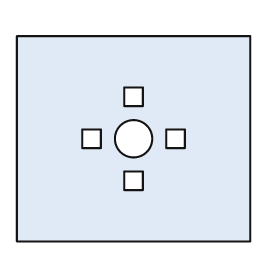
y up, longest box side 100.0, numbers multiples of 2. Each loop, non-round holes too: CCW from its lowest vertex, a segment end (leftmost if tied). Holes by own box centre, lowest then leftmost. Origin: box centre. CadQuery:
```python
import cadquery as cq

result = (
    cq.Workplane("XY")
    .moveTo(-50.0, -44.0)
    .lineTo(50.0, -44.0)
    .lineTo(50.0, 44.0)
    .lineTo(-50.0, 44.0)
    .close()
    .moveTo(-4.0, -22.0)
    .lineTo(4.0, -22.0)
    .lineTo(4.0, -14.0)
    .lineTo(-4.0, -14.0)
    .close()
    .moveTo(-22.0, -4.0)
    .lineTo(-14.0, -4.0)
    .lineTo(-14.0, 4.0)
    .lineTo(-22.0, 4.0)
    .close()
    .moveTo(0.0, 0.0)
    .circle(8.0)
    .moveTo(14.0, -4.0)
    .lineTo(22.0, -4.0)
    .lineTo(22.0, 4.0)
    .lineTo(14.0, 4.0)
    .close()
    .moveTo(-4.0, 14.0)
    .lineTo(4.0, 14.0)
    .lineTo(4.0, 22.0)
    .lineTo(-4.0, 22.0)
    .close()
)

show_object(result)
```